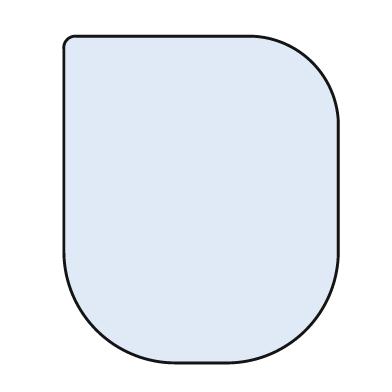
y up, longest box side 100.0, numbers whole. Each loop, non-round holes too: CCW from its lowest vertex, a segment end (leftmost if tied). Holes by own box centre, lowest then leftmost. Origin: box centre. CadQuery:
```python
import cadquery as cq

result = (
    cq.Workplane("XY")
    .moveTo(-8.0, -50.0)
    .lineTo(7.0, -50.0)
    .threePointArc((32.0, -40.0), (42.0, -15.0))
    .lineTo(42.0, 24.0)
    .threePointArc((34.0, 42.0), (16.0, 50.0))
    .lineTo(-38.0, 50.0)
    .threePointArc((-41.0, 49.0), (-42.0, 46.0))
    .lineTo(-42.0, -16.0)
    .threePointArc((-32.0, -40.0), (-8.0, -50.0))
    .close()
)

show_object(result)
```